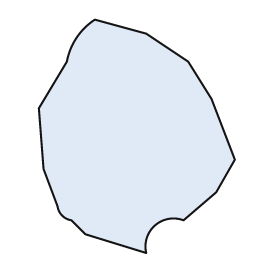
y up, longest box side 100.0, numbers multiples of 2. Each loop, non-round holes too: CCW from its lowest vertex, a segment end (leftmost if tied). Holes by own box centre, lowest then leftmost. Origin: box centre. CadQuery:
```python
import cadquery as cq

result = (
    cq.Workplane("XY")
    .moveTo(4.0, -50.0)
    .threePointArc((8.0, -38.0), (20.0, -36.0))
    .lineTo(34.0, -24.0)
    .lineTo(42.0, -10.0)
    .lineTo(32.0, 16.0)
    .lineTo(22.0, 32.0)
    .lineTo(4.0, 44.0)
    .lineTo(-18.0, 50.0)
    .threePointArc((-26.0, 42.0), (-30.0, 32.0))
    .lineTo(-42.0, 12.0)
    .lineTo(-40.0, -14.0)
    .lineTo(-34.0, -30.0)
    .threePointArc((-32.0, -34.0), (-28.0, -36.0))
    .lineTo(-22.0, -42.0)
    .close()
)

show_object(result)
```